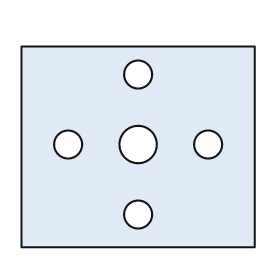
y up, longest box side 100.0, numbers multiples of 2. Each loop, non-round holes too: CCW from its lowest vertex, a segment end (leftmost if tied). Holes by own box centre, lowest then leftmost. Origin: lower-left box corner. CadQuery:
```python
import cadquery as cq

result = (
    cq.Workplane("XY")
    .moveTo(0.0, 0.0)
    .lineTo(100.0, 0.0)
    .lineTo(100.0, 86.0)
    .lineTo(0.0, 86.0)
    .close()
    .moveTo(50.0, 14.0)
    .circle(6.0)
    .moveTo(20.0, 44.0)
    .circle(6.0)
    .moveTo(50.0, 44.0)
    .circle(8.0)
    .moveTo(80.0, 44.0)
    .circle(6.0)
    .moveTo(50.0, 74.0)
    .circle(6.0)
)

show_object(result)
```